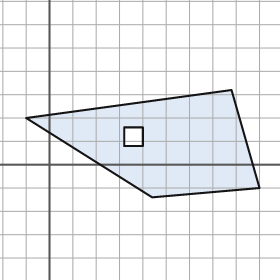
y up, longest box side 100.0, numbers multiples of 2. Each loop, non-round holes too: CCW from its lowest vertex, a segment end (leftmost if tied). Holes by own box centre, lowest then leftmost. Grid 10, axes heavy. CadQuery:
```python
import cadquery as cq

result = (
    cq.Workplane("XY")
    .moveTo(44.0, -14.0)
    .lineTo(90.0, -10.0)
    .lineTo(78.0, 32.0)
    .lineTo(-10.0, 20.0)
    .close()
    .moveTo(32.0, 8.0)
    .lineTo(40.0, 8.0)
    .lineTo(40.0, 16.0)
    .lineTo(32.0, 16.0)
    .close()
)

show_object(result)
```